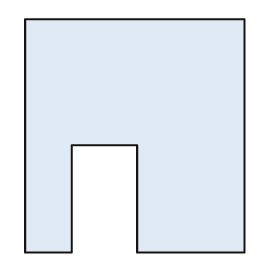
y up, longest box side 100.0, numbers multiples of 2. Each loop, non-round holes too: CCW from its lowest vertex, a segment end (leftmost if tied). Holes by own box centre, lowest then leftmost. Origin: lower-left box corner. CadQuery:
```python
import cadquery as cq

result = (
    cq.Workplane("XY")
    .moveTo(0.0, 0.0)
    .lineTo(20.0, 0.0)
    .lineTo(20.0, 46.0)
    .lineTo(48.0, 46.0)
    .lineTo(48.0, 0.0)
    .lineTo(94.0, 0.0)
    .lineTo(94.0, 100.0)
    .lineTo(0.0, 100.0)
    .close()
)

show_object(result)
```